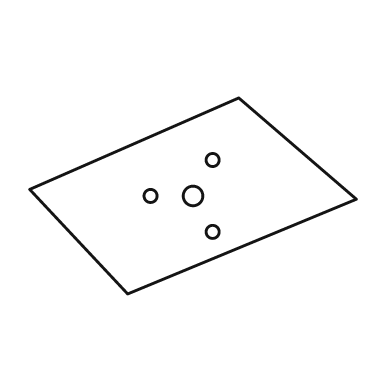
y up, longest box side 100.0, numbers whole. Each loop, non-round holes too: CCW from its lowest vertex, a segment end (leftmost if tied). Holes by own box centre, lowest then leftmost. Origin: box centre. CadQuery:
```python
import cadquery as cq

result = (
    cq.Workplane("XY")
    .moveTo(-20.0, -30.0)
    .lineTo(50.0, -1.0)
    .lineTo(14.0, 30.0)
    .lineTo(-50.0, 2.0)
    .close()
    .moveTo(6.0, -11.0)
    .circle(2.0)
    .moveTo(-13.0, 0.0)
    .circle(2.0)
    .moveTo(0.0, 0.0)
    .circle(3.0)
    .moveTo(6.0, 11.0)
    .circle(2.0)
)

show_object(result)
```